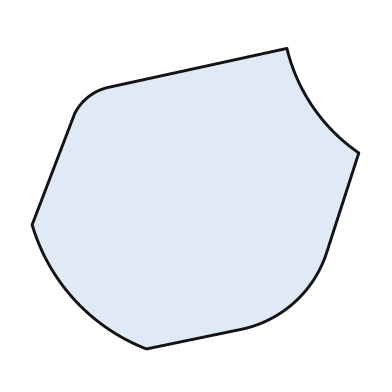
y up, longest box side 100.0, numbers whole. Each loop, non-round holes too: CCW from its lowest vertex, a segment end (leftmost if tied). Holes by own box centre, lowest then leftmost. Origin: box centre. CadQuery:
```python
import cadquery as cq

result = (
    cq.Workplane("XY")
    .moveTo(-15.0, -46.0)
    .lineTo(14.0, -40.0)
    .threePointArc((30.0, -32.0), (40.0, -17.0))
    .lineTo(50.0, 14.0)
    .threePointArc((36.0, 28.0), (28.0, 46.0))
    .lineTo(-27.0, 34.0)
    .threePointArc((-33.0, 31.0), (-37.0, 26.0))
    .lineTo(-50.0, -8.0)
    .threePointArc((-37.0, -31.0), (-15.0, -46.0))
    .close()
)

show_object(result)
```